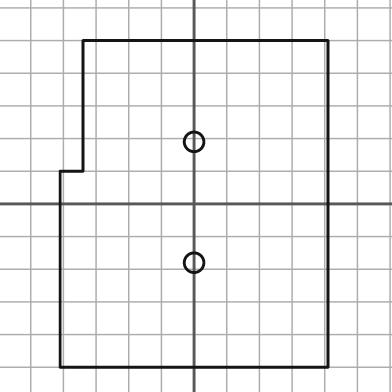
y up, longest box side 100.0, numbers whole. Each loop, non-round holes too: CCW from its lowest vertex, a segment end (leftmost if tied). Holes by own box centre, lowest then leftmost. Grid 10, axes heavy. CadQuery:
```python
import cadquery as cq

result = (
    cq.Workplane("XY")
    .moveTo(-41.0, -50.0)
    .lineTo(41.0, -50.0)
    .lineTo(41.0, 50.0)
    .lineTo(-34.0, 50.0)
    .lineTo(-34.0, 10.0)
    .lineTo(-41.0, 10.0)
    .close()
    .moveTo(0.0, -18.0)
    .circle(3.0)
    .moveTo(0.0, 19.0)
    .circle(3.0)
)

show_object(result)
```